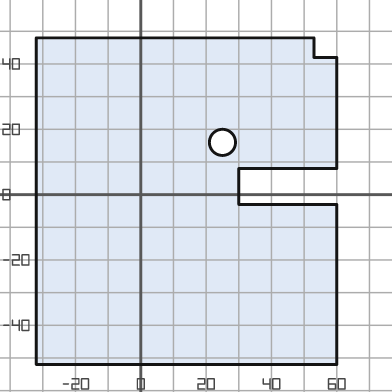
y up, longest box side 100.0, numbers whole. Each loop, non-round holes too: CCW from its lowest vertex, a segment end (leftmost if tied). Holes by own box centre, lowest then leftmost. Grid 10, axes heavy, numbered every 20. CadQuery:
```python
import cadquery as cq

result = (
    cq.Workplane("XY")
    .moveTo(-32.0, -52.0)
    .lineTo(60.0, -52.0)
    .lineTo(60.0, -3.0)
    .lineTo(30.0, -3.0)
    .lineTo(30.0, 8.0)
    .lineTo(60.0, 8.0)
    .lineTo(60.0, 42.0)
    .lineTo(53.0, 42.0)
    .lineTo(53.0, 48.0)
    .lineTo(-32.0, 48.0)
    .close()
    .moveTo(25.0, 16.0)
    .circle(4.0)
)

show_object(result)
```